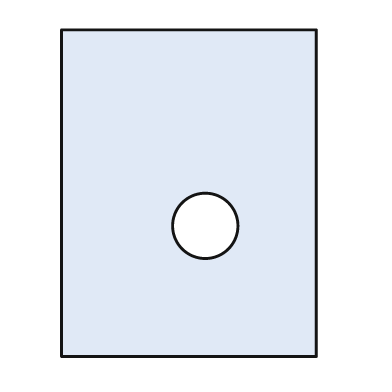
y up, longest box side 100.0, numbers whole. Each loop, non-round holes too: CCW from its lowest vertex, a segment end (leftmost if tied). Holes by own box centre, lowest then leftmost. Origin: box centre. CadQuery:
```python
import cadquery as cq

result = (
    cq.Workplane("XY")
    .moveTo(-39.0, -50.0)
    .lineTo(39.0, -50.0)
    .lineTo(39.0, 50.0)
    .lineTo(-39.0, 50.0)
    .close()
    .moveTo(5.0, -10.0)
    .circle(10.0)
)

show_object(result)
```